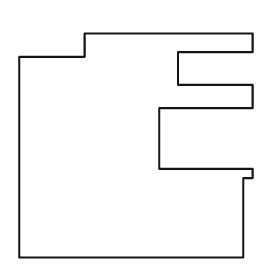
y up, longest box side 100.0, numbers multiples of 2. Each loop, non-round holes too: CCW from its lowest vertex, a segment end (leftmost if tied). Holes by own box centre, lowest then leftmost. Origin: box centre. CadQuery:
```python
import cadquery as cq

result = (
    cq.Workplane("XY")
    .moveTo(-50.0, -48.0)
    .lineTo(46.0, -48.0)
    .lineTo(46.0, -14.0)
    .lineTo(50.0, -14.0)
    .lineTo(50.0, -10.0)
    .lineTo(10.0, -10.0)
    .lineTo(10.0, 16.0)
    .lineTo(50.0, 16.0)
    .lineTo(50.0, 26.0)
    .lineTo(18.0, 26.0)
    .lineTo(18.0, 40.0)
    .lineTo(50.0, 40.0)
    .lineTo(50.0, 48.0)
    .lineTo(-22.0, 48.0)
    .lineTo(-22.0, 38.0)
    .lineTo(-50.0, 38.0)
    .close()
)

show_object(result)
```